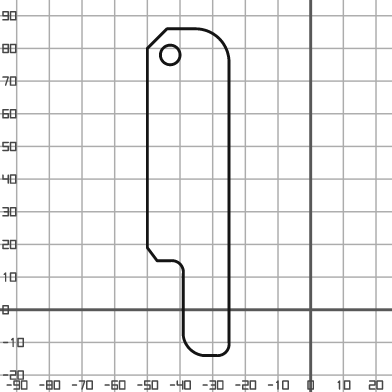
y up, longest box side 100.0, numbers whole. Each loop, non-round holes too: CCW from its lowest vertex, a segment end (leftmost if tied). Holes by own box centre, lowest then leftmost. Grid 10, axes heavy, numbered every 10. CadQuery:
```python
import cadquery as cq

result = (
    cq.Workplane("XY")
    .moveTo(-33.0, -14.0)
    .lineTo(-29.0, -14.0)
    .threePointArc((-26.0, -13.0), (-25.0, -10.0))
    .lineTo(-25.0, 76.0)
    .threePointArc((-28.0, 83.0), (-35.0, 86.0))
    .lineTo(-44.0, 86.0)
    .lineTo(-50.0, 80.0)
    .lineTo(-50.0, 19.0)
    .lineTo(-47.0, 15.0)
    .lineTo(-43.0, 15.0)
    .threePointArc((-40.0, 14.0), (-39.0, 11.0))
    .lineTo(-39.0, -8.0)
    .threePointArc((-37.0, -12.0), (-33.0, -14.0))
    .close()
    .moveTo(-43.0, 78.0)
    .circle(3.0)
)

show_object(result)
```